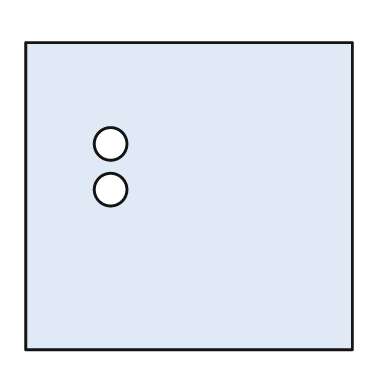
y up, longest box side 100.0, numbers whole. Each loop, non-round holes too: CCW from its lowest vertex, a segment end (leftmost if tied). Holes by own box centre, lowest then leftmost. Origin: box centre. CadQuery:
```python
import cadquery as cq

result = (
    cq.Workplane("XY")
    .moveTo(-50.0, -47.0)
    .lineTo(50.0, -47.0)
    .lineTo(50.0, 47.0)
    .lineTo(-50.0, 47.0)
    .close()
    .moveTo(-24.0, 2.0)
    .circle(5.0)
    .moveTo(-24.0, 16.0)
    .circle(5.0)
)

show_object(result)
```